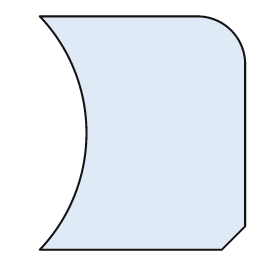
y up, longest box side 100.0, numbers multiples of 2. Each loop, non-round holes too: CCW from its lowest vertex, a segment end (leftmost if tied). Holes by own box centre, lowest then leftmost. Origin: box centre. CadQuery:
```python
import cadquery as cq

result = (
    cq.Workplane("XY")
    .moveTo(-44.0, -50.0)
    .lineTo(34.0, -50.0)
    .lineTo(44.0, -40.0)
    .lineTo(44.0, 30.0)
    .threePointArc((38.0, 44.0), (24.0, 50.0))
    .lineTo(-44.0, 50.0)
    .threePointArc((-24.0, 0.0), (-44.0, -50.0))
    .close()
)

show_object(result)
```